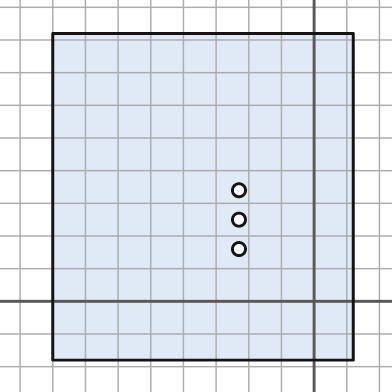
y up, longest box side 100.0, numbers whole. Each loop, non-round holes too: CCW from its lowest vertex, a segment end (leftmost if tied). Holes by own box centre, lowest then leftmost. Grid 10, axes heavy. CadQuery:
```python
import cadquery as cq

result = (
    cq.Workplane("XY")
    .moveTo(-80.0, -18.0)
    .lineTo(12.0, -18.0)
    .lineTo(12.0, 82.0)
    .lineTo(-80.0, 82.0)
    .close()
    .moveTo(-23.0, 16.0)
    .circle(2.0)
    .moveTo(-23.0, 25.0)
    .circle(2.0)
    .moveTo(-23.0, 34.0)
    .circle(2.0)
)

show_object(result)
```